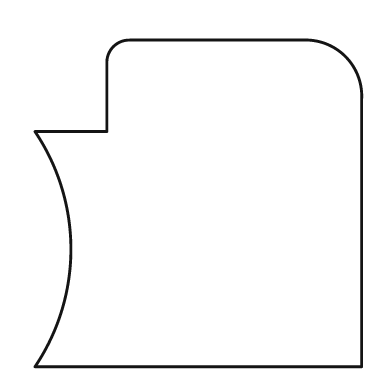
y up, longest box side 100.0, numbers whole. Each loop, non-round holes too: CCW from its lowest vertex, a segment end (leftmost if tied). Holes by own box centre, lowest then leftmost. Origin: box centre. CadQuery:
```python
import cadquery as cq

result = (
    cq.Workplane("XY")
    .moveTo(-50.0, -50.0)
    .lineTo(50.0, -50.0)
    .lineTo(50.0, 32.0)
    .threePointArc((45.0, 45.0), (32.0, 50.0))
    .lineTo(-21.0, 50.0)
    .threePointArc((-26.0, 48.0), (-28.0, 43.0))
    .lineTo(-28.0, 22.0)
    .lineTo(-50.0, 22.0)
    .threePointArc((-39.0, -14.0), (-50.0, -50.0))
    .close()
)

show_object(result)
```